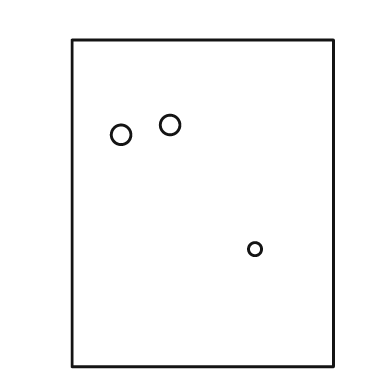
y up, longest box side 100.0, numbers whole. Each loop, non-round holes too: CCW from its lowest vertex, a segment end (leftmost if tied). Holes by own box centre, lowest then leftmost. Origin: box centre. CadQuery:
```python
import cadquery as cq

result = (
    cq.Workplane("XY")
    .moveTo(-40.0, -50.0)
    .lineTo(40.0, -50.0)
    .lineTo(40.0, 50.0)
    .lineTo(-40.0, 50.0)
    .close()
    .moveTo(16.0, -14.0)
    .circle(2.0)
    .moveTo(-25.0, 21.0)
    .circle(3.0)
    .moveTo(-10.0, 24.0)
    .circle(3.0)
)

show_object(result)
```